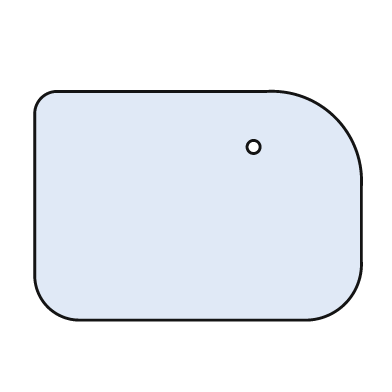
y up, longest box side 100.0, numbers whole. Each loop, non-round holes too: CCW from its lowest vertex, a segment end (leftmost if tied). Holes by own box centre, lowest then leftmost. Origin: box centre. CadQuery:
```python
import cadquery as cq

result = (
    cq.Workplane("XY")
    .moveTo(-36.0, -35.0)
    .lineTo(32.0, -35.0)
    .threePointArc((45.0, -30.0), (50.0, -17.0))
    .lineTo(50.0, 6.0)
    .threePointArc((42.0, 27.0), (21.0, 35.0))
    .lineTo(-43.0, 35.0)
    .threePointArc((-48.0, 33.0), (-50.0, 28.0))
    .lineTo(-50.0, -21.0)
    .threePointArc((-46.0, -31.0), (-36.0, -35.0))
    .close()
    .moveTo(17.0, 18.0)
    .circle(2.0)
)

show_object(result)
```